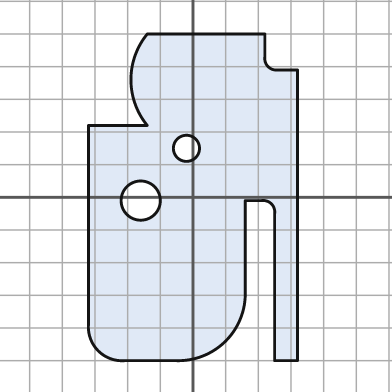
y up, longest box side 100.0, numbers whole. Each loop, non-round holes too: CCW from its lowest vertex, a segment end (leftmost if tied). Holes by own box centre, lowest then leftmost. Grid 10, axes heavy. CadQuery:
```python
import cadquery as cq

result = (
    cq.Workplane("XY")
    .moveTo(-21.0, -50.0)
    .lineTo(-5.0, -50.0)
    .threePointArc((10.0, -44.0), (16.0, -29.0))
    .lineTo(16.0, -1.0)
    .lineTo(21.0, -1.0)
    .threePointArc((24.0, -2.0), (25.0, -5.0))
    .lineTo(25.0, -50.0)
    .lineTo(32.0, -50.0)
    .lineTo(32.0, 39.0)
    .lineTo(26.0, 39.0)
    .threePointArc((23.0, 40.0), (22.0, 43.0))
    .lineTo(22.0, 50.0)
    .lineTo(-14.0, 50.0)
    .threePointArc((-19.0, 36.0), (-14.0, 22.0))
    .lineTo(-32.0, 22.0)
    .lineTo(-32.0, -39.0)
    .threePointArc((-29.0, -47.0), (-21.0, -50.0))
    .close()
    .moveTo(-16.0, -1.0)
    .circle(6.0)
    .moveTo(-2.0, 15.0)
    .circle(4.0)
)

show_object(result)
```